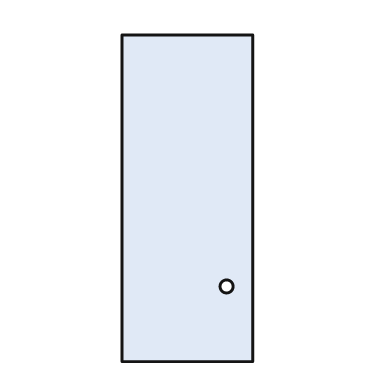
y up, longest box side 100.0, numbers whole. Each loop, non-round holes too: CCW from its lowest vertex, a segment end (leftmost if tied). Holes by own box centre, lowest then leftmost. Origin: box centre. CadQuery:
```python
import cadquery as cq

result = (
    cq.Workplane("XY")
    .moveTo(-20.0, -50.0)
    .lineTo(20.0, -50.0)
    .lineTo(20.0, 50.0)
    .lineTo(-20.0, 50.0)
    .close()
    .moveTo(12.0, -27.0)
    .circle(2.0)
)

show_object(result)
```